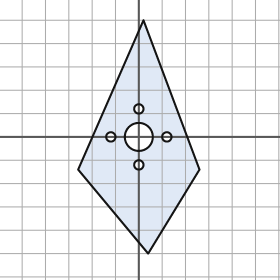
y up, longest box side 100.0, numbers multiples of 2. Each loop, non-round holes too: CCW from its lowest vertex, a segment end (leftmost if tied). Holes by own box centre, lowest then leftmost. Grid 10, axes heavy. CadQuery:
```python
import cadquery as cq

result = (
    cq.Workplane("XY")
    .moveTo(4.0, -50.0)
    .lineTo(26.0, -14.0)
    .lineTo(2.0, 50.0)
    .lineTo(-26.0, -14.0)
    .close()
    .moveTo(0.0, -12.0)
    .circle(2.0)
    .moveTo(-12.0, 0.0)
    .circle(2.0)
    .moveTo(0.0, 0.0)
    .circle(6.0)
    .moveTo(12.0, 0.0)
    .circle(2.0)
    .moveTo(0.0, 12.0)
    .circle(2.0)
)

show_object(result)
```